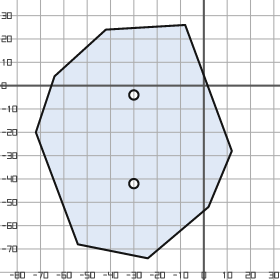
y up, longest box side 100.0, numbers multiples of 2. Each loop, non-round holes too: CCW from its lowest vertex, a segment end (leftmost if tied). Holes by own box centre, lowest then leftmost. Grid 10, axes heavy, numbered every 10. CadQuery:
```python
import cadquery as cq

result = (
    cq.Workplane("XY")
    .moveTo(-24.0, -74.0)
    .lineTo(2.0, -52.0)
    .lineTo(12.0, -28.0)
    .lineTo(-8.0, 26.0)
    .lineTo(-42.0, 24.0)
    .lineTo(-64.0, 4.0)
    .lineTo(-72.0, -20.0)
    .lineTo(-54.0, -68.0)
    .close()
    .moveTo(-30.0, -42.0)
    .circle(2.0)
    .moveTo(-30.0, -4.0)
    .circle(2.0)
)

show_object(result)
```